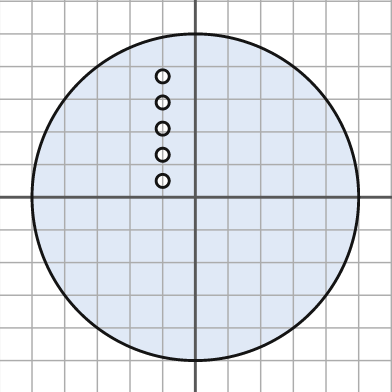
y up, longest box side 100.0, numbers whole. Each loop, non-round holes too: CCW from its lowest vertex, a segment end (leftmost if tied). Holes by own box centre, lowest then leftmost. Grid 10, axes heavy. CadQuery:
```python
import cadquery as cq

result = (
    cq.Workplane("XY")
    .moveTo(0.0, 0.0)
    .circle(50.0)
    .moveTo(-10.0, 5.0)
    .circle(2.0)
    .moveTo(-10.0, 13.0)
    .circle(2.0)
    .moveTo(-10.0, 21.0)
    .circle(2.0)
    .moveTo(-10.0, 29.0)
    .circle(2.0)
    .moveTo(-10.0, 37.0)
    .circle(2.0)
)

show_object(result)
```